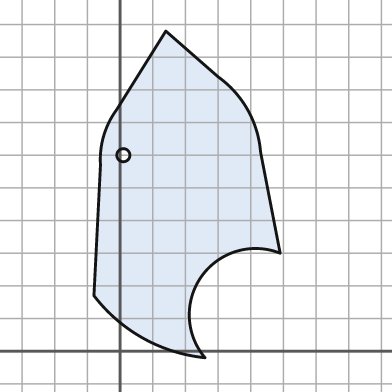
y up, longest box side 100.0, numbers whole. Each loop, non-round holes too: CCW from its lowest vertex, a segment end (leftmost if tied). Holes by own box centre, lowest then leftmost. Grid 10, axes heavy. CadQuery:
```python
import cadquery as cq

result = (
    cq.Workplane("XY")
    .moveTo(26.0, -2.0)
    .threePointArc((25.0, 23.0), (49.0, 30.0))
    .lineTo(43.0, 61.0)
    .threePointArc((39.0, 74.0), (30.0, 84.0))
    .lineTo(14.0, 98.0)
    .lineTo(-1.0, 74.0)
    .threePointArc((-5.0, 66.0), (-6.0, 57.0))
    .lineTo(-8.0, 17.0)
    .threePointArc((7.0, 4.0), (26.0, -2.0))
    .close()
    .moveTo(1.0, 60.0)
    .circle(2.0)
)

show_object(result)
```